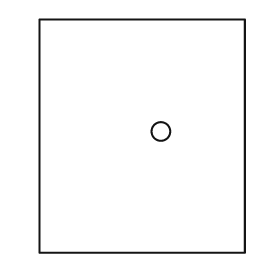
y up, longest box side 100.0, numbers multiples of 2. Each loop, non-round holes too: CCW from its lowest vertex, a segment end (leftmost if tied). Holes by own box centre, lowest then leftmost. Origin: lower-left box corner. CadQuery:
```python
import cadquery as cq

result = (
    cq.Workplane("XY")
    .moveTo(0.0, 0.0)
    .lineTo(88.0, 0.0)
    .lineTo(88.0, 100.0)
    .lineTo(0.0, 100.0)
    .close()
    .moveTo(52.0, 52.0)
    .circle(4.0)
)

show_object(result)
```